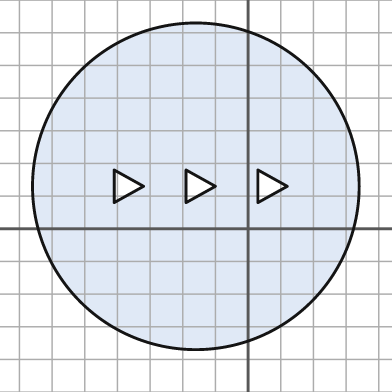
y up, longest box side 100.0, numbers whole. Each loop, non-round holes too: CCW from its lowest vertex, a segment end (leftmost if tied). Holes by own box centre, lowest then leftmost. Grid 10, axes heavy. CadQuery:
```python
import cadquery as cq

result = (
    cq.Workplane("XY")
    .moveTo(-16.0, 13.0)
    .circle(50.0)
    .moveTo(-41.0, 8.0)
    .lineTo(-32.0, 13.0)
    .lineTo(-41.0, 18.0)
    .close()
    .moveTo(-19.0, 8.0)
    .lineTo(-10.0, 13.0)
    .lineTo(-19.0, 18.0)
    .close()
    .moveTo(3.0, 8.0)
    .lineTo(12.0, 13.0)
    .lineTo(3.0, 18.0)
    .close()
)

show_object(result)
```